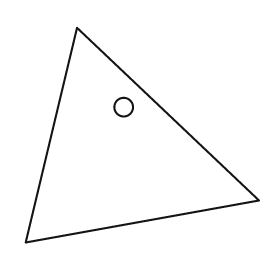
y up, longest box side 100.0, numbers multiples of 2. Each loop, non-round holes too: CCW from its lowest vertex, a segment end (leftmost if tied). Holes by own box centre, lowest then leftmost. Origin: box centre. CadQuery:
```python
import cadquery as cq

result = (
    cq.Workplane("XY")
    .moveTo(-50.0, -46.0)
    .lineTo(50.0, -28.0)
    .lineTo(-28.0, 46.0)
    .close()
    .moveTo(-8.0, 12.0)
    .circle(4.0)
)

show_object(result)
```